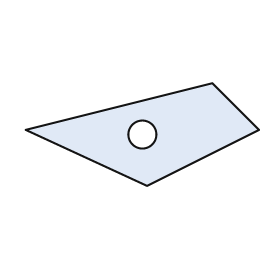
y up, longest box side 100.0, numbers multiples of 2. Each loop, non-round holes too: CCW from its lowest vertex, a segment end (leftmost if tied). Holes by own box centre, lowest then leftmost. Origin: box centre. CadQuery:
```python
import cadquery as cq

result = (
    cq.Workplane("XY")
    .moveTo(2.0, -22.0)
    .lineTo(50.0, 2.0)
    .lineTo(30.0, 22.0)
    .lineTo(-50.0, 2.0)
    .close()
    .moveTo(0.0, 0.0)
    .circle(6.0)
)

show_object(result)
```